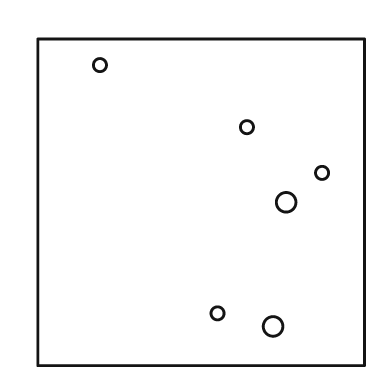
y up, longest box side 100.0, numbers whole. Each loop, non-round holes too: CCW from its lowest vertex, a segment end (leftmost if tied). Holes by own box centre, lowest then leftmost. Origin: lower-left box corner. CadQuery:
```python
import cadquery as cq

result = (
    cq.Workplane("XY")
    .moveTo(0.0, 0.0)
    .lineTo(100.0, 0.0)
    .lineTo(100.0, 100.0)
    .lineTo(0.0, 100.0)
    .close()
    .moveTo(72.0, 12.0)
    .circle(3.0)
    .moveTo(55.0, 16.0)
    .circle(2.0)
    .moveTo(76.0, 50.0)
    .circle(3.0)
    .moveTo(87.0, 59.0)
    .circle(2.0)
    .moveTo(64.0, 73.0)
    .circle(2.0)
    .moveTo(19.0, 92.0)
    .circle(2.0)
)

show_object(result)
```